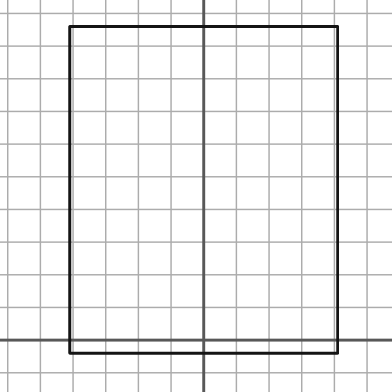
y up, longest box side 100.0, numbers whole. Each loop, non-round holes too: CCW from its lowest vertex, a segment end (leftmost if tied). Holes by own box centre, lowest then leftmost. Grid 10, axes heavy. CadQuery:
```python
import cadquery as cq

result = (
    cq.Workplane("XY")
    .moveTo(-41.0, -4.0)
    .lineTo(41.0, -4.0)
    .lineTo(41.0, 96.0)
    .lineTo(-41.0, 96.0)
    .close()
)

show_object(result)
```